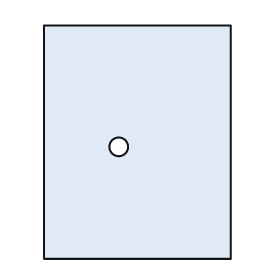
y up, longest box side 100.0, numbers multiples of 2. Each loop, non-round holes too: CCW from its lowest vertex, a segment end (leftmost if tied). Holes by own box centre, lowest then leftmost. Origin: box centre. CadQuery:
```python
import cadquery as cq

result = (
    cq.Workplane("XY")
    .moveTo(-40.0, -50.0)
    .lineTo(40.0, -50.0)
    .lineTo(40.0, 50.0)
    .lineTo(-40.0, 50.0)
    .close()
    .moveTo(-8.0, -2.0)
    .circle(4.0)
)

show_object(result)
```